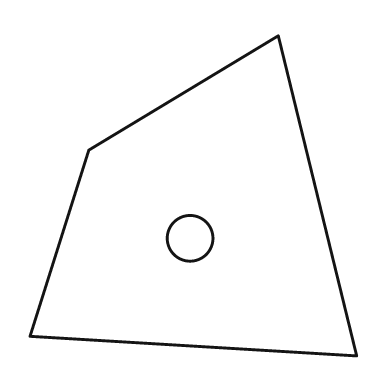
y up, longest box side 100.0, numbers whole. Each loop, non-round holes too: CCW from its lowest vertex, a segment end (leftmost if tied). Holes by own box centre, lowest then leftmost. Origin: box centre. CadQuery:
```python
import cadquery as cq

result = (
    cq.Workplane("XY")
    .moveTo(50.0, -49.0)
    .lineTo(26.0, 49.0)
    .lineTo(-32.0, 14.0)
    .lineTo(-50.0, -43.0)
    .close()
    .moveTo(-1.0, -13.0)
    .circle(7.0)
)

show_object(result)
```